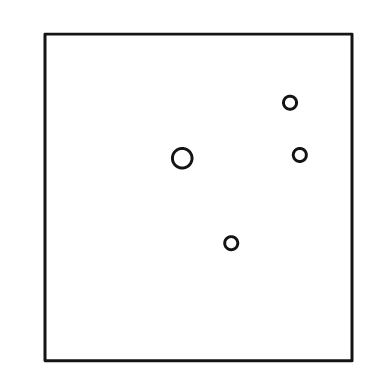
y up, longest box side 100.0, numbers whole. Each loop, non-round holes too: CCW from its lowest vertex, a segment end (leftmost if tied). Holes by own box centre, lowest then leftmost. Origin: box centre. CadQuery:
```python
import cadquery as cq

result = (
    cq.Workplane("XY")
    .moveTo(-47.0, -50.0)
    .lineTo(47.0, -50.0)
    .lineTo(47.0, 50.0)
    .lineTo(-47.0, 50.0)
    .close()
    .moveTo(10.0, -14.0)
    .circle(2.0)
    .moveTo(-5.0, 12.0)
    .circle(3.0)
    .moveTo(31.0, 13.0)
    .circle(2.0)
    .moveTo(28.0, 29.0)
    .circle(2.0)
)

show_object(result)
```